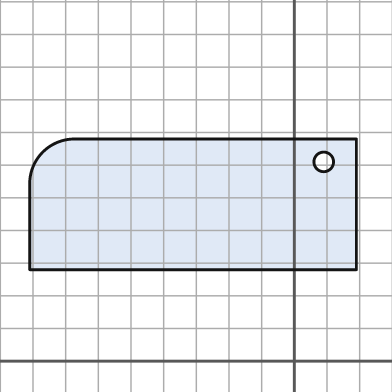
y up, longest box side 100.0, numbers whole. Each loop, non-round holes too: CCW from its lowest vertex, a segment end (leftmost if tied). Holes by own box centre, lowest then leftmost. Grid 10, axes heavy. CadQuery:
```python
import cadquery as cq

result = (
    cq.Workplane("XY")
    .moveTo(-81.0, 28.0)
    .lineTo(19.0, 28.0)
    .lineTo(19.0, 68.0)
    .lineTo(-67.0, 68.0)
    .threePointArc((-77.0, 64.0), (-81.0, 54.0))
    .close()
    .moveTo(9.0, 61.0)
    .circle(3.0)
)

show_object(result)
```